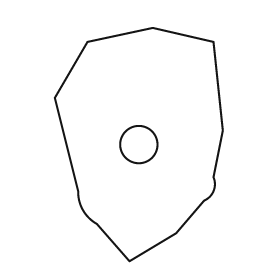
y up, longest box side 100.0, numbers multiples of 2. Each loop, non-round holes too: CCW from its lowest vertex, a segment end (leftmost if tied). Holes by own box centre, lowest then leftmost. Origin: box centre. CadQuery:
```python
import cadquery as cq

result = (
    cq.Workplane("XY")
    .moveTo(-4.0, -50.0)
    .lineTo(16.0, -38.0)
    .lineTo(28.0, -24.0)
    .threePointArc((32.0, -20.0), (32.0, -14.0))
    .lineTo(36.0, 6.0)
    .lineTo(32.0, 44.0)
    .lineTo(6.0, 50.0)
    .lineTo(-22.0, 44.0)
    .lineTo(-36.0, 20.0)
    .lineTo(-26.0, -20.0)
    .threePointArc((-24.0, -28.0), (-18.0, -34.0))
    .close()
    .moveTo(0.0, 0.0)
    .circle(8.0)
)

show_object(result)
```